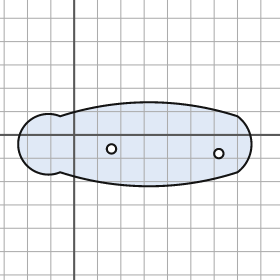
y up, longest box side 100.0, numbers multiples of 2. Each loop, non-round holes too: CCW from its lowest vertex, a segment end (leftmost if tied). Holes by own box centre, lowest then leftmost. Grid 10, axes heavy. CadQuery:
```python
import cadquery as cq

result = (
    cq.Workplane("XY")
    .moveTo(-6.0, -16.0)
    .threePointArc((32.0, -22.0), (70.0, -16.0))
    .threePointArc((76.0, -4.0), (70.0, 8.0))
    .threePointArc((32.0, 14.0), (-6.0, 8.0))
    .threePointArc((-24.0, -4.0), (-6.0, -16.0))
    .close()
    .moveTo(62.0, -8.0)
    .circle(2.0)
    .moveTo(16.0, -6.0)
    .circle(2.0)
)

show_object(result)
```